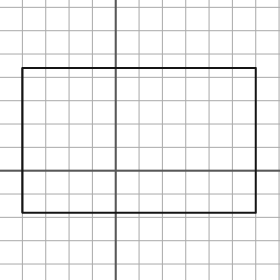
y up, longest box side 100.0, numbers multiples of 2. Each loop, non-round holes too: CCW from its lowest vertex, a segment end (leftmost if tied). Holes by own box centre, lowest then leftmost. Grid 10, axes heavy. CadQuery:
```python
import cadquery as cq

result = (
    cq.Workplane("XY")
    .moveTo(-40.0, -18.0)
    .lineTo(60.0, -18.0)
    .lineTo(60.0, 44.0)
    .lineTo(-40.0, 44.0)
    .close()
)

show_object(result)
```